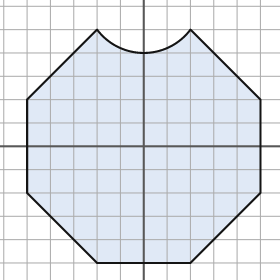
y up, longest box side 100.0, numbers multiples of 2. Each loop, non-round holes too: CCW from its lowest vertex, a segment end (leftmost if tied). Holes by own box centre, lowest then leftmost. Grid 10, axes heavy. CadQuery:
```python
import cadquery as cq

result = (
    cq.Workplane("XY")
    .moveTo(-20.0, -50.0)
    .lineTo(20.0, -50.0)
    .lineTo(50.0, -20.0)
    .lineTo(50.0, 20.0)
    .lineTo(20.0, 50.0)
    .threePointArc((0.0, 40.0), (-20.0, 50.0))
    .lineTo(-50.0, 20.0)
    .lineTo(-50.0, -20.0)
    .close()
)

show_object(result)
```